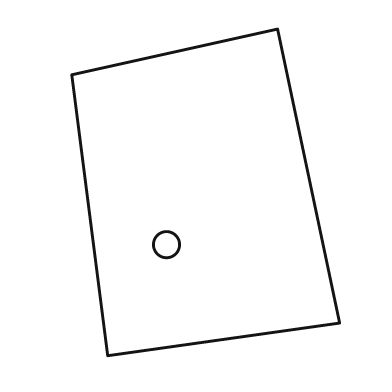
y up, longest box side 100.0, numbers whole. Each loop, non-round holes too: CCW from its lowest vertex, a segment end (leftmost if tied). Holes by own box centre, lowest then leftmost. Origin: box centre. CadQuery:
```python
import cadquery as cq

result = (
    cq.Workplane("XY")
    .moveTo(-30.0, -50.0)
    .lineTo(41.0, -40.0)
    .lineTo(22.0, 50.0)
    .lineTo(-41.0, 36.0)
    .close()
    .moveTo(-12.0, -16.0)
    .circle(4.0)
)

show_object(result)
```